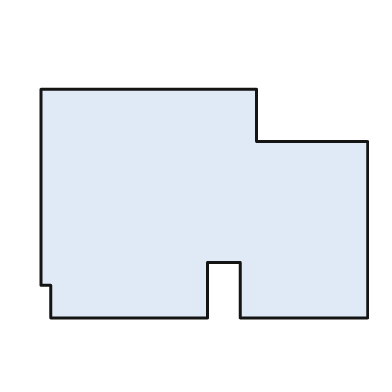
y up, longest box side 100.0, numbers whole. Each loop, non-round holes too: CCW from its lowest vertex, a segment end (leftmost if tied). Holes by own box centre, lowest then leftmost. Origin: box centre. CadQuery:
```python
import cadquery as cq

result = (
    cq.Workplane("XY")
    .moveTo(-47.0, -35.0)
    .lineTo(1.0, -35.0)
    .lineTo(1.0, -18.0)
    .lineTo(11.0, -18.0)
    .lineTo(11.0, -35.0)
    .lineTo(50.0, -35.0)
    .lineTo(50.0, 19.0)
    .lineTo(16.0, 19.0)
    .lineTo(16.0, 35.0)
    .lineTo(-50.0, 35.0)
    .lineTo(-50.0, -25.0)
    .lineTo(-47.0, -25.0)
    .close()
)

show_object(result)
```